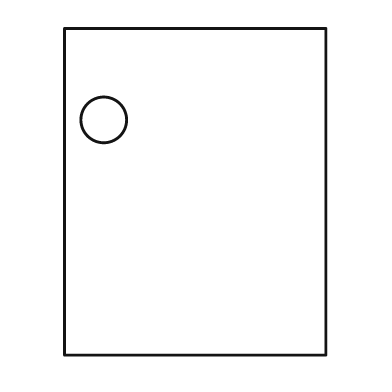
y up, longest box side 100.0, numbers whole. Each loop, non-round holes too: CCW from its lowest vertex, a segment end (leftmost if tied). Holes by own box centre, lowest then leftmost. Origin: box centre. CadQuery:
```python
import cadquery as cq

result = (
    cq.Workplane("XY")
    .moveTo(-40.0, -50.0)
    .lineTo(40.0, -50.0)
    .lineTo(40.0, 50.0)
    .lineTo(-40.0, 50.0)
    .close()
    .moveTo(-28.0, 22.0)
    .circle(7.0)
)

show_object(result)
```